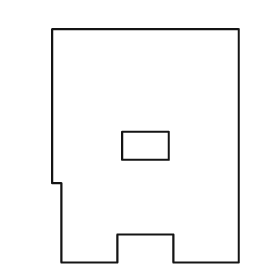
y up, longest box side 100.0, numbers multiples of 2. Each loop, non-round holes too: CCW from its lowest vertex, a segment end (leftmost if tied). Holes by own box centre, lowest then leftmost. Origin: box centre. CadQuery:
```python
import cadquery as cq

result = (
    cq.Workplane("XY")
    .moveTo(-36.0, -50.0)
    .lineTo(-12.0, -50.0)
    .lineTo(-12.0, -38.0)
    .lineTo(12.0, -38.0)
    .lineTo(12.0, -50.0)
    .lineTo(40.0, -50.0)
    .lineTo(40.0, 50.0)
    .lineTo(-40.0, 50.0)
    .lineTo(-40.0, -16.0)
    .lineTo(-36.0, -16.0)
    .close()
    .moveTo(-10.0, -6.0)
    .lineTo(10.0, -6.0)
    .lineTo(10.0, 6.0)
    .lineTo(-10.0, 6.0)
    .close()
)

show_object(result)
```